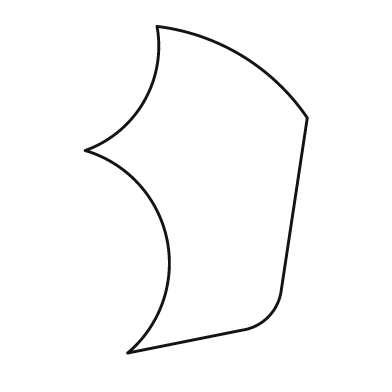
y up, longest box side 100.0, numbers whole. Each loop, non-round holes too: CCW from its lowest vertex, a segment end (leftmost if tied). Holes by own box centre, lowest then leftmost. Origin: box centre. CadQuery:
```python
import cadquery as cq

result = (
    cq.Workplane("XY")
    .moveTo(-21.0, -50.0)
    .lineTo(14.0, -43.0)
    .threePointArc((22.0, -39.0), (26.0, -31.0))
    .lineTo(34.0, 22.0)
    .threePointArc((14.0, 41.0), (-12.0, 50.0))
    .threePointArc((-16.0, 27.0), (-34.0, 12.0))
    .threePointArc((-9.0, -15.0), (-21.0, -50.0))
    .close()
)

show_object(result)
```